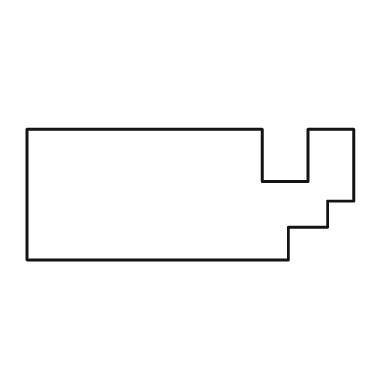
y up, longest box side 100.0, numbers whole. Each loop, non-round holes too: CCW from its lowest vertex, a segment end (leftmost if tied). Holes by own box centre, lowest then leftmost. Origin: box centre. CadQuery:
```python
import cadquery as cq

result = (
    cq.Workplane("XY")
    .moveTo(-50.0, -20.0)
    .lineTo(30.0, -20.0)
    .lineTo(30.0, -10.0)
    .lineTo(42.0, -10.0)
    .lineTo(42.0, -2.0)
    .lineTo(50.0, -2.0)
    .lineTo(50.0, 20.0)
    .lineTo(36.0, 20.0)
    .lineTo(36.0, 4.0)
    .lineTo(22.0, 4.0)
    .lineTo(22.0, 20.0)
    .lineTo(-50.0, 20.0)
    .close()
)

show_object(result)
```